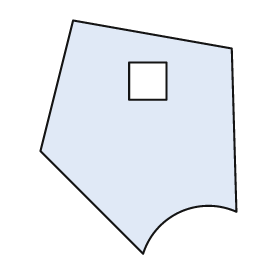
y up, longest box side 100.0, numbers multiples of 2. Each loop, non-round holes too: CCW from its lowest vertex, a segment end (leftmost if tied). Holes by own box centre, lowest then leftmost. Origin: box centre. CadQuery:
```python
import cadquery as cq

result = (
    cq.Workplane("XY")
    .moveTo(2.0, -50.0)
    .threePointArc((18.0, -32.0), (42.0, -32.0))
    .lineTo(40.0, 38.0)
    .lineTo(-28.0, 50.0)
    .lineTo(-42.0, -6.0)
    .close()
    .moveTo(-4.0, 16.0)
    .lineTo(12.0, 16.0)
    .lineTo(12.0, 32.0)
    .lineTo(-4.0, 32.0)
    .close()
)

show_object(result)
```